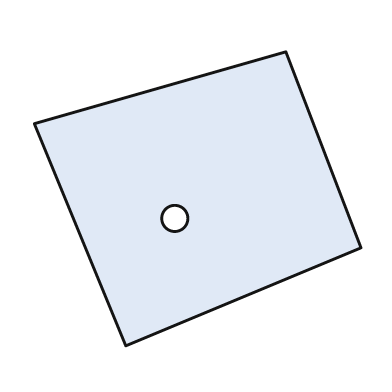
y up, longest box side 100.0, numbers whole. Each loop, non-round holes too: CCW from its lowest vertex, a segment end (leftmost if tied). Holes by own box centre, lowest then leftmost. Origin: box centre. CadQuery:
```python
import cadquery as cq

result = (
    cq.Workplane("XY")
    .moveTo(-22.0, -45.0)
    .lineTo(50.0, -15.0)
    .lineTo(27.0, 45.0)
    .lineTo(-50.0, 23.0)
    .close()
    .moveTo(-7.0, -6.0)
    .circle(4.0)
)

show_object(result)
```